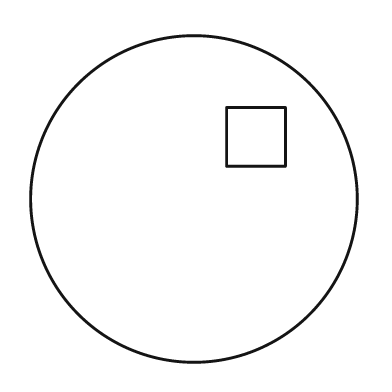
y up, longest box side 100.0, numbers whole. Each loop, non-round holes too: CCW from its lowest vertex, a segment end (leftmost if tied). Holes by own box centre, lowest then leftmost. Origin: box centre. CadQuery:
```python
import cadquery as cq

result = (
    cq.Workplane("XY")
    .moveTo(0.0, 0.0)
    .circle(50.0)
    .moveTo(10.0, 10.0)
    .lineTo(28.0, 10.0)
    .lineTo(28.0, 28.0)
    .lineTo(10.0, 28.0)
    .close()
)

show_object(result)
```